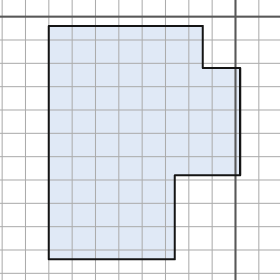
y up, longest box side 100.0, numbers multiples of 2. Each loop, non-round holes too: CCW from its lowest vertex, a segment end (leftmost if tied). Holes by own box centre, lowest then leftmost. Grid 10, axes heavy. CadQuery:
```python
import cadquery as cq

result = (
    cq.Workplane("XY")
    .moveTo(-80.0, -104.0)
    .lineTo(-26.0, -104.0)
    .lineTo(-26.0, -68.0)
    .lineTo(2.0, -68.0)
    .lineTo(2.0, -22.0)
    .lineTo(-14.0, -22.0)
    .lineTo(-14.0, -4.0)
    .lineTo(-80.0, -4.0)
    .close()
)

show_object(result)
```